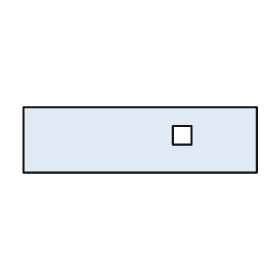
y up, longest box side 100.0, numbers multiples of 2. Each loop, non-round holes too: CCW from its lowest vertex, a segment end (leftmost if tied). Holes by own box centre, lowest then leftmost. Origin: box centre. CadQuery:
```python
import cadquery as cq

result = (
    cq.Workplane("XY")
    .moveTo(-50.0, -14.0)
    .lineTo(50.0, -14.0)
    .lineTo(50.0, 14.0)
    .lineTo(-50.0, 14.0)
    .close()
    .moveTo(14.0, -2.0)
    .lineTo(22.0, -2.0)
    .lineTo(22.0, 6.0)
    .lineTo(14.0, 6.0)
    .close()
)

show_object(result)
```